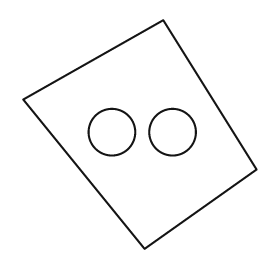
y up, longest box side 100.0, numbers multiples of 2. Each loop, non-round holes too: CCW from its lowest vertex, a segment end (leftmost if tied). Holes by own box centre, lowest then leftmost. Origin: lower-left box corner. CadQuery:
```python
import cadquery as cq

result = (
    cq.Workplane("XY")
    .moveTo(52.0, 0.0)
    .lineTo(100.0, 34.0)
    .lineTo(60.0, 98.0)
    .lineTo(0.0, 64.0)
    .close()
    .moveTo(38.0, 50.0)
    .circle(10.0)
    .moveTo(64.0, 50.0)
    .circle(10.0)
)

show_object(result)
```